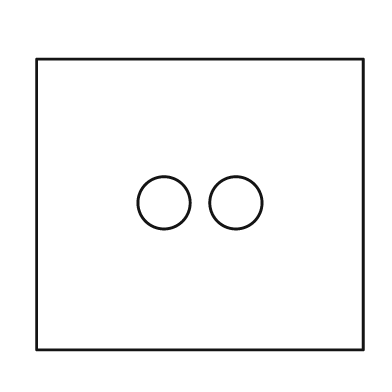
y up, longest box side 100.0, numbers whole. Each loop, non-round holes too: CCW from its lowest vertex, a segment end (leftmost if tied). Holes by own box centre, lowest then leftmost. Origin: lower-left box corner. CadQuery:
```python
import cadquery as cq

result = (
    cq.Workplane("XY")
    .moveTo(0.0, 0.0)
    .lineTo(100.0, 0.0)
    .lineTo(100.0, 89.0)
    .lineTo(0.0, 89.0)
    .close()
    .moveTo(39.0, 45.0)
    .circle(8.0)
    .moveTo(61.0, 45.0)
    .circle(8.0)
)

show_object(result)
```